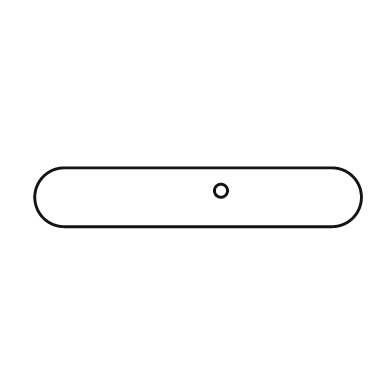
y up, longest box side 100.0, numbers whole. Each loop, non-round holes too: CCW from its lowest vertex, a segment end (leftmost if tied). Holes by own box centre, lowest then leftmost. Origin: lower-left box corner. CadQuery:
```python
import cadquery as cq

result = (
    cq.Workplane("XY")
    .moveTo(9.0, 0.0)
    .lineTo(91.0, 0.0)
    .threePointArc((100.0, 9.0), (91.0, 18.0))
    .lineTo(9.0, 18.0)
    .threePointArc((0.0, 9.0), (9.0, 0.0))
    .close()
    .moveTo(57.0, 11.0)
    .circle(2.0)
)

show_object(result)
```